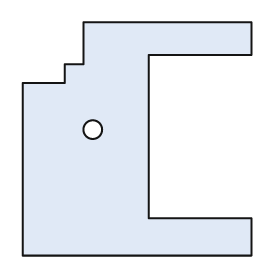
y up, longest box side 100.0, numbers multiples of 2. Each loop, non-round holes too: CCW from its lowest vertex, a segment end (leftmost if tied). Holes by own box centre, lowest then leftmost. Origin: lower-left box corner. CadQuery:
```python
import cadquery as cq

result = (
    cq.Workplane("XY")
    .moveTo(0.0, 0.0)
    .lineTo(98.0, 0.0)
    .lineTo(98.0, 16.0)
    .lineTo(54.0, 16.0)
    .lineTo(54.0, 86.0)
    .lineTo(98.0, 86.0)
    .lineTo(98.0, 100.0)
    .lineTo(26.0, 100.0)
    .lineTo(26.0, 82.0)
    .lineTo(18.0, 82.0)
    .lineTo(18.0, 74.0)
    .lineTo(0.0, 74.0)
    .close()
    .moveTo(30.0, 54.0)
    .circle(4.0)
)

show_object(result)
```